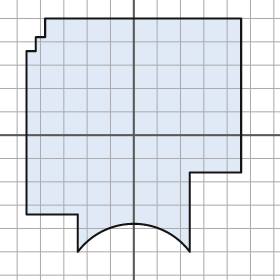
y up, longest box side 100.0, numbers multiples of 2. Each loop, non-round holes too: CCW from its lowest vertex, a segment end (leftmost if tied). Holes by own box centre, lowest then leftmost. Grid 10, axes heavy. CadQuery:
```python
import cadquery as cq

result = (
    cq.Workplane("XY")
    .moveTo(-24.0, -50.0)
    .threePointArc((0.0, -38.0), (24.0, -50.0))
    .lineTo(24.0, -16.0)
    .lineTo(46.0, -16.0)
    .lineTo(46.0, 50.0)
    .lineTo(-38.0, 50.0)
    .lineTo(-38.0, 42.0)
    .lineTo(-42.0, 42.0)
    .lineTo(-42.0, 36.0)
    .lineTo(-46.0, 36.0)
    .lineTo(-46.0, -34.0)
    .lineTo(-24.0, -34.0)
    .close()
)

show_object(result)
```